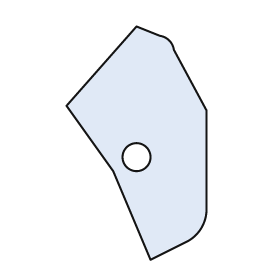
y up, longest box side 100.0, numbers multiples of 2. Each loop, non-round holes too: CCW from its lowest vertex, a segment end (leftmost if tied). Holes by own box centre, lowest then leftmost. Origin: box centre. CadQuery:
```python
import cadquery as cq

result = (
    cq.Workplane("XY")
    .moveTo(6.0, -50.0)
    .lineTo(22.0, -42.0)
    .threePointArc((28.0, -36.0), (30.0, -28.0))
    .lineTo(30.0, 14.0)
    .lineTo(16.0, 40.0)
    .threePointArc((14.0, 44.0), (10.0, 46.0))
    .lineTo(0.0, 50.0)
    .lineTo(-30.0, 16.0)
    .lineTo(-10.0, -12.0)
    .close()
    .moveTo(0.0, -6.0)
    .circle(6.0)
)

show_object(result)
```